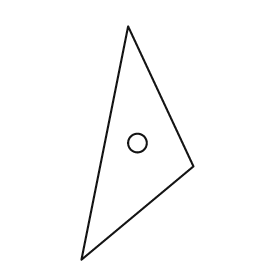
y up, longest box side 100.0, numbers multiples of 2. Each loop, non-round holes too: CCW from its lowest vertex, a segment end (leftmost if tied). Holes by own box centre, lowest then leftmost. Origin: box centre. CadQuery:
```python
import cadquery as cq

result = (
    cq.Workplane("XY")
    .moveTo(-24.0, -50.0)
    .lineTo(24.0, -10.0)
    .lineTo(-4.0, 50.0)
    .close()
    .moveTo(0.0, 0.0)
    .circle(4.0)
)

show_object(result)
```